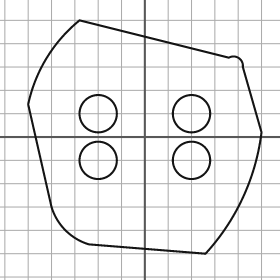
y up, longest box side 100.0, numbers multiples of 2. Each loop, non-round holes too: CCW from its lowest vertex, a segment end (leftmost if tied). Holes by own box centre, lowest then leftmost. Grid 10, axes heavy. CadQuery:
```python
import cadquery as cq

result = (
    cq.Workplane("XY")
    .moveTo(26.0, -50.0)
    .threePointArc((42.0, -26.0), (50.0, 2.0))
    .lineTo(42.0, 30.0)
    .threePointArc((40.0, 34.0), (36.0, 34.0))
    .lineTo(-28.0, 50.0)
    .threePointArc((-42.0, 34.0), (-50.0, 14.0))
    .lineTo(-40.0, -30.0)
    .threePointArc((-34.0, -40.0), (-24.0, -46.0))
    .close()
    .moveTo(-20.0, -10.0)
    .circle(8.0)
    .moveTo(20.0, -10.0)
    .circle(8.0)
    .moveTo(-20.0, 10.0)
    .circle(8.0)
    .moveTo(20.0, 10.0)
    .circle(8.0)
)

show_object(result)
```